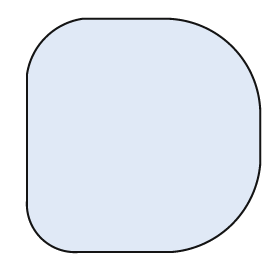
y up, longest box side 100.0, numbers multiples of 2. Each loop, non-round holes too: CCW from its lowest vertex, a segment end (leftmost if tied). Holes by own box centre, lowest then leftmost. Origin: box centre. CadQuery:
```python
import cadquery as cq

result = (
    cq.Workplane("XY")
    .moveTo(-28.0, -50.0)
    .lineTo(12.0, -50.0)
    .threePointArc((38.0, -38.0), (50.0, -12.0))
    .lineTo(50.0, 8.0)
    .threePointArc((38.0, 38.0), (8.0, 50.0))
    .lineTo(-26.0, 50.0)
    .threePointArc((-42.0, 42.0), (-50.0, 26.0))
    .lineTo(-50.0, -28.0)
    .threePointArc((-44.0, -44.0), (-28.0, -50.0))
    .close()
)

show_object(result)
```